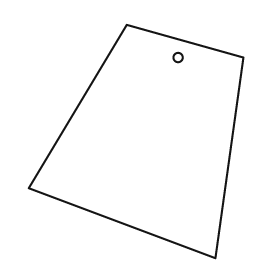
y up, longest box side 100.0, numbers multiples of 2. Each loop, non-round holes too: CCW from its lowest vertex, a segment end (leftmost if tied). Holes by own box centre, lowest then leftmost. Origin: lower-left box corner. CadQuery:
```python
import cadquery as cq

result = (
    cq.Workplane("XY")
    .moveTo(80.0, 0.0)
    .lineTo(92.0, 86.0)
    .lineTo(42.0, 100.0)
    .lineTo(0.0, 30.0)
    .close()
    .moveTo(64.0, 86.0)
    .circle(2.0)
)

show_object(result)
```